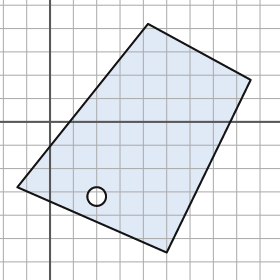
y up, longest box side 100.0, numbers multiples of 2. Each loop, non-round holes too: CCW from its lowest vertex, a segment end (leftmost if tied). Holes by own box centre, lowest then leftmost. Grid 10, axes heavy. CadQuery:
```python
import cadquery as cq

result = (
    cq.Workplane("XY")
    .moveTo(50.0, -56.0)
    .lineTo(86.0, 18.0)
    .lineTo(42.0, 42.0)
    .lineTo(-14.0, -28.0)
    .close()
    .moveTo(20.0, -32.0)
    .circle(4.0)
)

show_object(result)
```